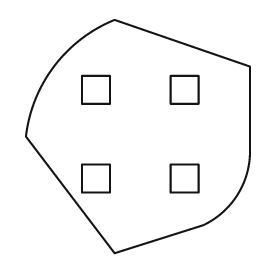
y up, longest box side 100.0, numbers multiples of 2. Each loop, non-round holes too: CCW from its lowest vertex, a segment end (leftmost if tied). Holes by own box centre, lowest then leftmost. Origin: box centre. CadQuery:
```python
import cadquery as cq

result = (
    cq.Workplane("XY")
    .moveTo(-10.0, -50.0)
    .lineTo(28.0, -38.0)
    .threePointArc((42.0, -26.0), (48.0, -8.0))
    .lineTo(48.0, 30.0)
    .lineTo(-10.0, 50.0)
    .threePointArc((-36.0, 30.0), (-48.0, 0.0))
    .close()
    .moveTo(-24.0, -24.0)
    .lineTo(-12.0, -24.0)
    .lineTo(-12.0, -12.0)
    .lineTo(-24.0, -12.0)
    .close()
    .moveTo(14.0, -24.0)
    .lineTo(26.0, -24.0)
    .lineTo(26.0, -12.0)
    .lineTo(14.0, -12.0)
    .close()
    .moveTo(-24.0, 14.0)
    .lineTo(-12.0, 14.0)
    .lineTo(-12.0, 26.0)
    .lineTo(-24.0, 26.0)
    .close()
    .moveTo(14.0, 14.0)
    .lineTo(26.0, 14.0)
    .lineTo(26.0, 26.0)
    .lineTo(14.0, 26.0)
    .close()
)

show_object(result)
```